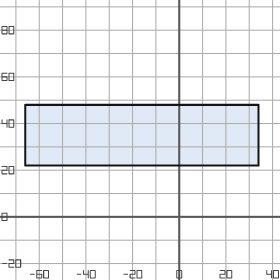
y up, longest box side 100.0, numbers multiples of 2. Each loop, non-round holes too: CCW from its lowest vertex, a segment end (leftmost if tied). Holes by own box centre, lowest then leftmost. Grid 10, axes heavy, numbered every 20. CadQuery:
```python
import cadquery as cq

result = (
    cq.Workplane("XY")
    .moveTo(-66.0, 22.0)
    .lineTo(34.0, 22.0)
    .lineTo(34.0, 48.0)
    .lineTo(-66.0, 48.0)
    .close()
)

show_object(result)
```